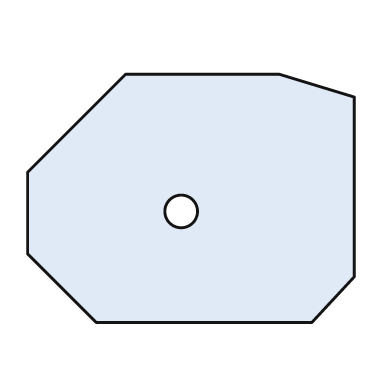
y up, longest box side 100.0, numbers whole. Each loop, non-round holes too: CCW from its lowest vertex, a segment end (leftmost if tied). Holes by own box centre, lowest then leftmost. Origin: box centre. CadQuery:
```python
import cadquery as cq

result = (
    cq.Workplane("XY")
    .moveTo(-29.0, -38.0)
    .lineTo(37.0, -38.0)
    .lineTo(50.0, -24.0)
    .lineTo(50.0, 31.0)
    .lineTo(27.0, 38.0)
    .lineTo(-20.0, 38.0)
    .lineTo(-50.0, 8.0)
    .lineTo(-50.0, -17.0)
    .close()
    .moveTo(-3.0, -4.0)
    .circle(5.0)
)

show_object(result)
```